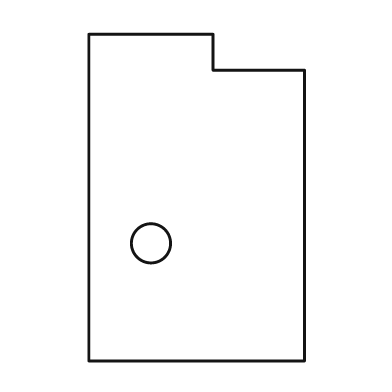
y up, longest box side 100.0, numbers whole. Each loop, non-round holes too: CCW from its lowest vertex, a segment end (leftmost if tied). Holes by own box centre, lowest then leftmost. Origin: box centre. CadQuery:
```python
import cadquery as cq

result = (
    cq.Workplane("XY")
    .moveTo(-33.0, -50.0)
    .lineTo(33.0, -50.0)
    .lineTo(33.0, 39.0)
    .lineTo(5.0, 39.0)
    .lineTo(5.0, 50.0)
    .lineTo(-33.0, 50.0)
    .close()
    .moveTo(-14.0, -14.0)
    .circle(6.0)
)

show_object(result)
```